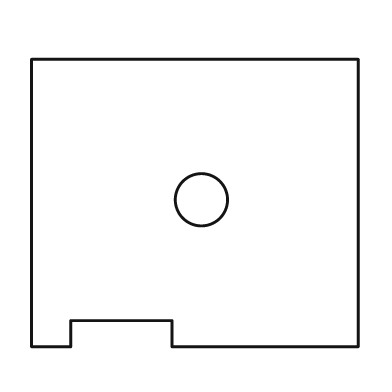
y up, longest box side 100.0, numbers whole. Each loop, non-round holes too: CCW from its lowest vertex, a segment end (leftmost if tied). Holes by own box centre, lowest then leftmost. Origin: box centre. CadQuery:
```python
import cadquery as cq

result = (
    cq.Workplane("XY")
    .moveTo(-50.0, -44.0)
    .lineTo(-38.0, -44.0)
    .lineTo(-38.0, -36.0)
    .lineTo(-7.0, -36.0)
    .lineTo(-7.0, -44.0)
    .lineTo(50.0, -44.0)
    .lineTo(50.0, 44.0)
    .lineTo(-50.0, 44.0)
    .close()
    .moveTo(2.0, 1.0)
    .circle(8.0)
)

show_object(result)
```